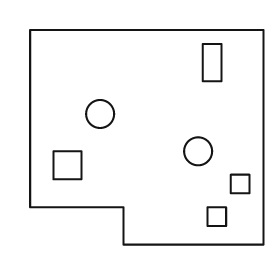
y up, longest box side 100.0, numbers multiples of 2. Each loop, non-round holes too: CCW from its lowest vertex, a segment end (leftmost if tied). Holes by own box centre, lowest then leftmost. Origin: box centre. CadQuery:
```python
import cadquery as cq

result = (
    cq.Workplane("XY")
    .moveTo(-10.0, -46.0)
    .lineTo(50.0, -46.0)
    .lineTo(50.0, 46.0)
    .lineTo(-50.0, 46.0)
    .lineTo(-50.0, -30.0)
    .lineTo(-10.0, -30.0)
    .close()
    .moveTo(26.0, -38.0)
    .lineTo(34.0, -38.0)
    .lineTo(34.0, -30.0)
    .lineTo(26.0, -30.0)
    .close()
    .moveTo(36.0, -24.0)
    .lineTo(44.0, -24.0)
    .lineTo(44.0, -16.0)
    .lineTo(36.0, -16.0)
    .close()
    .moveTo(-40.0, -18.0)
    .lineTo(-28.0, -18.0)
    .lineTo(-28.0, -6.0)
    .lineTo(-40.0, -6.0)
    .close()
    .moveTo(22.0, -6.0)
    .circle(6.0)
    .moveTo(-20.0, 10.0)
    .circle(6.0)
    .moveTo(24.0, 24.0)
    .lineTo(32.0, 24.0)
    .lineTo(32.0, 40.0)
    .lineTo(24.0, 40.0)
    .close()
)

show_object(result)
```